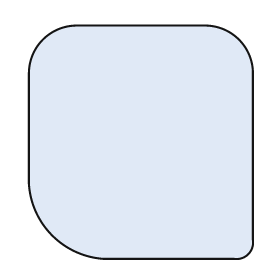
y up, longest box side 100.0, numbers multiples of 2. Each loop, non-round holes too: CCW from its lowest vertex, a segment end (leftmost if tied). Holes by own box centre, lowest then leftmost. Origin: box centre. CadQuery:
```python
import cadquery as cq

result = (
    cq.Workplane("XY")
    .moveTo(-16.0, -50.0)
    .lineTo(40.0, -50.0)
    .threePointArc((46.0, -48.0), (48.0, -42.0))
    .lineTo(48.0, 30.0)
    .threePointArc((42.0, 44.0), (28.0, 50.0))
    .lineTo(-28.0, 50.0)
    .threePointArc((-42.0, 44.0), (-48.0, 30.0))
    .lineTo(-48.0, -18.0)
    .threePointArc((-38.0, -40.0), (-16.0, -50.0))
    .close()
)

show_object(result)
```